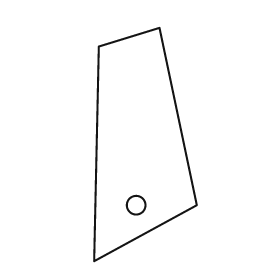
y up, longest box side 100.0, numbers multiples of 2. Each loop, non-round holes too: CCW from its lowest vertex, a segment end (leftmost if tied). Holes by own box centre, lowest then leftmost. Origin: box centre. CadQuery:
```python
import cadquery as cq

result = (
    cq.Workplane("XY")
    .moveTo(-22.0, -50.0)
    .lineTo(22.0, -26.0)
    .lineTo(6.0, 50.0)
    .lineTo(-20.0, 42.0)
    .close()
    .moveTo(-4.0, -26.0)
    .circle(4.0)
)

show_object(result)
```